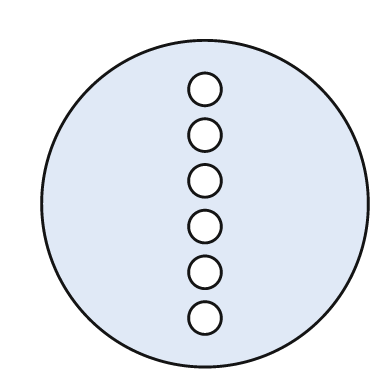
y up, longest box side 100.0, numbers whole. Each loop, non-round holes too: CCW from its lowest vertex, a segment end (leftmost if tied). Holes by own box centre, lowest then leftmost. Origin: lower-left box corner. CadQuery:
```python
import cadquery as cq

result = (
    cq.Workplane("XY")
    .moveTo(50.0, 50.0)
    .circle(50.0)
    .moveTo(50.0, 15.0)
    .circle(5.0)
    .moveTo(50.0, 29.0)
    .circle(5.0)
    .moveTo(50.0, 43.0)
    .circle(5.0)
    .moveTo(50.0, 57.0)
    .circle(5.0)
    .moveTo(50.0, 71.0)
    .circle(5.0)
    .moveTo(50.0, 85.0)
    .circle(5.0)
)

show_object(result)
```